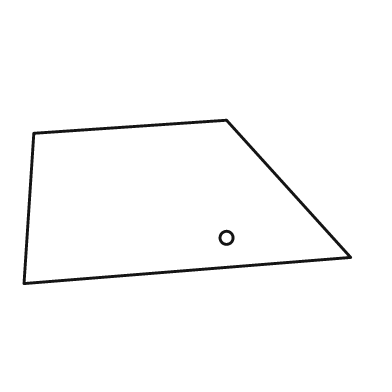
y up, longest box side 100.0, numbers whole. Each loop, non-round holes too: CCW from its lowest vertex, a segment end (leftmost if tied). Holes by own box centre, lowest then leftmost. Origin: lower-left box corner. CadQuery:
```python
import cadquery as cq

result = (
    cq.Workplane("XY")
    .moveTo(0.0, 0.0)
    .lineTo(100.0, 8.0)
    .lineTo(62.0, 50.0)
    .lineTo(3.0, 46.0)
    .close()
    .moveTo(62.0, 14.0)
    .circle(2.0)
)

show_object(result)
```